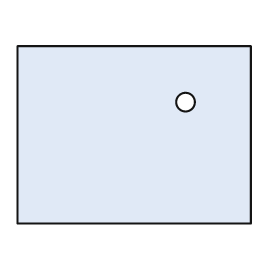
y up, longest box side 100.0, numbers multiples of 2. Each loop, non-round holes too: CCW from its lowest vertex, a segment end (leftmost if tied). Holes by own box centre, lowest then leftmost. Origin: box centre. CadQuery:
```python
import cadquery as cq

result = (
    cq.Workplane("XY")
    .moveTo(-50.0, -38.0)
    .lineTo(50.0, -38.0)
    .lineTo(50.0, 38.0)
    .lineTo(-50.0, 38.0)
    .close()
    .moveTo(22.0, 14.0)
    .circle(4.0)
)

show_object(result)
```